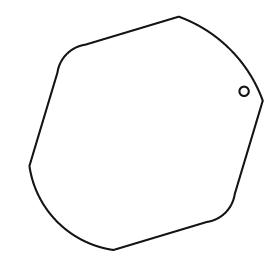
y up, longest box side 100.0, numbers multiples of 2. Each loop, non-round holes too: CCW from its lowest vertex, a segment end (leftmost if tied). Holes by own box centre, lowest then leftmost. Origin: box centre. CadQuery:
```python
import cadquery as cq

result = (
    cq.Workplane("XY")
    .moveTo(-14.0, -50.0)
    .lineTo(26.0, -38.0)
    .threePointArc((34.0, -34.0), (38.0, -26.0))
    .lineTo(50.0, 14.0)
    .threePointArc((36.0, 36.0), (14.0, 50.0))
    .lineTo(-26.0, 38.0)
    .threePointArc((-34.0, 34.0), (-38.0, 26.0))
    .lineTo(-50.0, -14.0)
    .threePointArc((-38.0, -38.0), (-14.0, -50.0))
    .close()
    .moveTo(42.0, 18.0)
    .circle(2.0)
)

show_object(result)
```